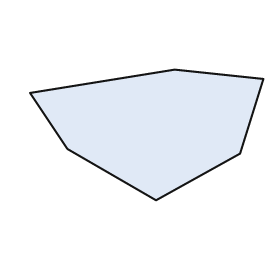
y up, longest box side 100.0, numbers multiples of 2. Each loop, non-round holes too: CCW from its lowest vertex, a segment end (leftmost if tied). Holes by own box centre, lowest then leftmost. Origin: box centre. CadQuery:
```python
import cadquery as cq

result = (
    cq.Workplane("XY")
    .moveTo(4.0, -28.0)
    .lineTo(40.0, -8.0)
    .lineTo(50.0, 24.0)
    .lineTo(12.0, 28.0)
    .lineTo(-50.0, 18.0)
    .lineTo(-34.0, -6.0)
    .close()
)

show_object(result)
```